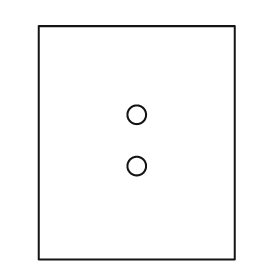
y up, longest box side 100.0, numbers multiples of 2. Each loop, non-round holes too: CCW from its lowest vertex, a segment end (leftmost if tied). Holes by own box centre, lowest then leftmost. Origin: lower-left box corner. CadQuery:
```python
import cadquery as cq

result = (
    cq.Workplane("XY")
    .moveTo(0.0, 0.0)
    .lineTo(84.0, 0.0)
    .lineTo(84.0, 100.0)
    .lineTo(0.0, 100.0)
    .close()
    .moveTo(42.0, 40.0)
    .circle(4.0)
    .moveTo(42.0, 62.0)
    .circle(4.0)
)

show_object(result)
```